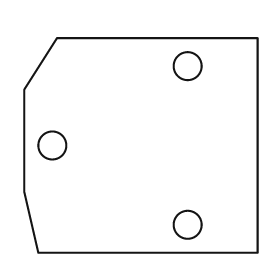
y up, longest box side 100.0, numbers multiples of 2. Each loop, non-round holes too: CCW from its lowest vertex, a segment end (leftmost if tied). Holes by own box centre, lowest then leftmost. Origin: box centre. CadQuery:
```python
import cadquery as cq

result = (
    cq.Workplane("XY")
    .moveTo(-44.0, -46.0)
    .lineTo(50.0, -46.0)
    .lineTo(50.0, 46.0)
    .lineTo(-36.0, 46.0)
    .lineTo(-50.0, 24.0)
    .lineTo(-50.0, -20.0)
    .close()
    .moveTo(20.0, -34.0)
    .circle(6.0)
    .moveTo(-38.0, 0.0)
    .circle(6.0)
    .moveTo(20.0, 34.0)
    .circle(6.0)
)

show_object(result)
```